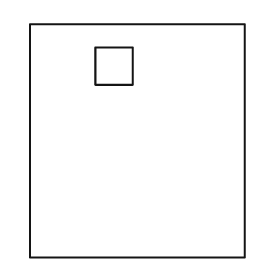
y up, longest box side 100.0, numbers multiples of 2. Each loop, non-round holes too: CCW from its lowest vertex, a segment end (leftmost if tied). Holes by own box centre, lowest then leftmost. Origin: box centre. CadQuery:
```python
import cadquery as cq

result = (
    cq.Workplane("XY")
    .moveTo(-46.0, -50.0)
    .lineTo(46.0, -50.0)
    .lineTo(46.0, 50.0)
    .lineTo(-46.0, 50.0)
    .close()
    .moveTo(-18.0, 24.0)
    .lineTo(-2.0, 24.0)
    .lineTo(-2.0, 40.0)
    .lineTo(-18.0, 40.0)
    .close()
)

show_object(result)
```